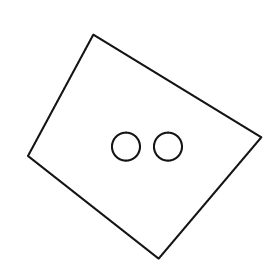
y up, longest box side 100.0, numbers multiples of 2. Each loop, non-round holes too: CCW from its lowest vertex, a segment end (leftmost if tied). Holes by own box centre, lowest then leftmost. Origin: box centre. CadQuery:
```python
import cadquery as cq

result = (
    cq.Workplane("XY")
    .moveTo(6.0, -48.0)
    .lineTo(50.0, 4.0)
    .lineTo(-22.0, 48.0)
    .lineTo(-50.0, -4.0)
    .close()
    .moveTo(-8.0, 0.0)
    .circle(6.0)
    .moveTo(10.0, 0.0)
    .circle(6.0)
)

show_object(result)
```